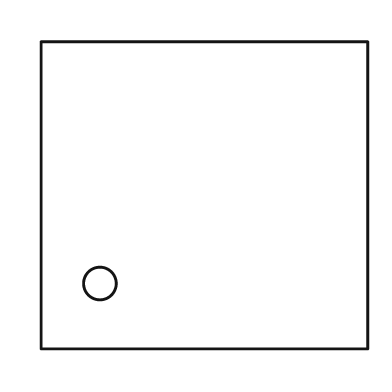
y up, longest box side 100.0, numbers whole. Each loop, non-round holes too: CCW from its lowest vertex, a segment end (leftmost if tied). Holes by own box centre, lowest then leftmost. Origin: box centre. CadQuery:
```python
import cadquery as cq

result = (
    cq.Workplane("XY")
    .moveTo(-50.0, -47.0)
    .lineTo(50.0, -47.0)
    .lineTo(50.0, 47.0)
    .lineTo(-50.0, 47.0)
    .close()
    .moveTo(-32.0, -27.0)
    .circle(5.0)
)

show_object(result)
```